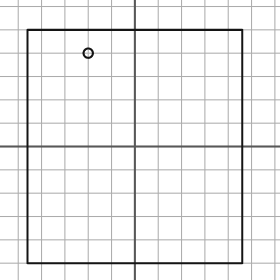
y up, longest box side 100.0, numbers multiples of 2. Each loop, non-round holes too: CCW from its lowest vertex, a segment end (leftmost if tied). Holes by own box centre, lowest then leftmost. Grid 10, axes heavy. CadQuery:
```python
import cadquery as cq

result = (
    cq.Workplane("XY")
    .moveTo(-46.0, -50.0)
    .lineTo(46.0, -50.0)
    .lineTo(46.0, 50.0)
    .lineTo(-46.0, 50.0)
    .close()
    .moveTo(-20.0, 40.0)
    .circle(2.0)
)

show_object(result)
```